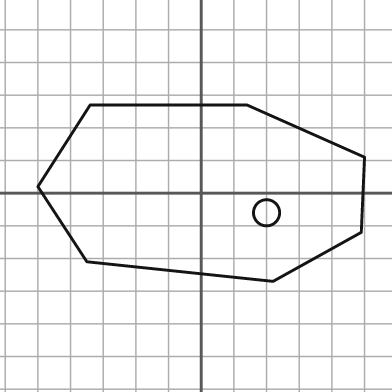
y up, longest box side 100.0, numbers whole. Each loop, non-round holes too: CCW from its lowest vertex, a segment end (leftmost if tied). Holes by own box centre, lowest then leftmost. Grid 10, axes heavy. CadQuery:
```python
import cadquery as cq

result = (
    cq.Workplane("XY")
    .moveTo(22.0, -27.0)
    .lineTo(49.0, -12.0)
    .lineTo(50.0, 11.0)
    .lineTo(14.0, 27.0)
    .lineTo(-34.0, 27.0)
    .lineTo(-50.0, 2.0)
    .lineTo(-35.0, -21.0)
    .close()
    .moveTo(20.0, -6.0)
    .circle(4.0)
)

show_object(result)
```